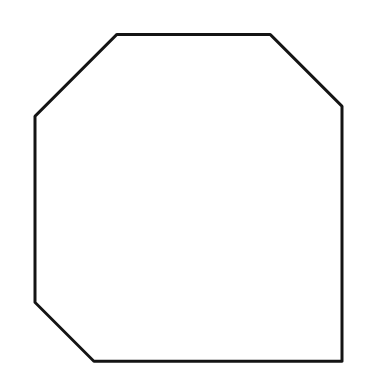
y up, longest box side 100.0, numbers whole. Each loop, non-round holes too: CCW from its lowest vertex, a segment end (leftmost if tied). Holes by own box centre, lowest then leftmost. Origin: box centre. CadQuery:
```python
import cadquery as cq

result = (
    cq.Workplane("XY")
    .moveTo(-29.0, -50.0)
    .lineTo(47.0, -50.0)
    .lineTo(47.0, 28.0)
    .lineTo(25.0, 50.0)
    .lineTo(-22.0, 50.0)
    .lineTo(-47.0, 25.0)
    .lineTo(-47.0, -32.0)
    .close()
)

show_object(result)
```